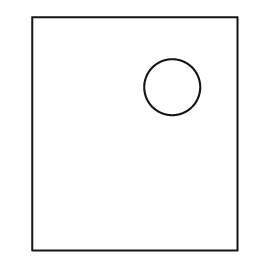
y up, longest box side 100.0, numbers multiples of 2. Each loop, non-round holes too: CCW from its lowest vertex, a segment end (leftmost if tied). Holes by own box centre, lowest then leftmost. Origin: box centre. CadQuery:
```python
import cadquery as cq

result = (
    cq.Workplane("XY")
    .moveTo(-44.0, -50.0)
    .lineTo(44.0, -50.0)
    .lineTo(44.0, 50.0)
    .lineTo(-44.0, 50.0)
    .close()
    .moveTo(16.0, 20.0)
    .circle(12.0)
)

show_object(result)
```